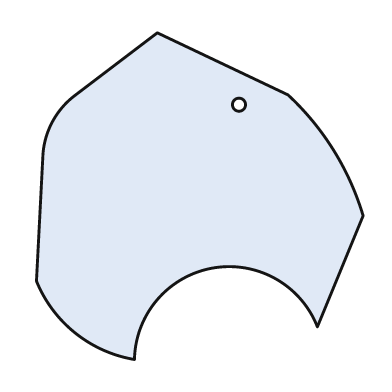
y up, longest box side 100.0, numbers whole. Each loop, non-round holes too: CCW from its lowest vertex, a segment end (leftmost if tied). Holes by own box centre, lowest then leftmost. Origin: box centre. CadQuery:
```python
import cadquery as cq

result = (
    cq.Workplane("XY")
    .moveTo(-20.0, -50.0)
    .threePointArc((4.0, -22.0), (36.0, -40.0))
    .lineTo(50.0, -6.0)
    .threePointArc((41.0, 14.0), (27.0, 31.0))
    .lineTo(-13.0, 50.0)
    .lineTo(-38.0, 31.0)
    .threePointArc((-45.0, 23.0), (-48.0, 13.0))
    .lineTo(-50.0, -26.0)
    .threePointArc((-38.0, -42.0), (-20.0, -50.0))
    .close()
    .moveTo(12.0, 28.0)
    .circle(2.0)
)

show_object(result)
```